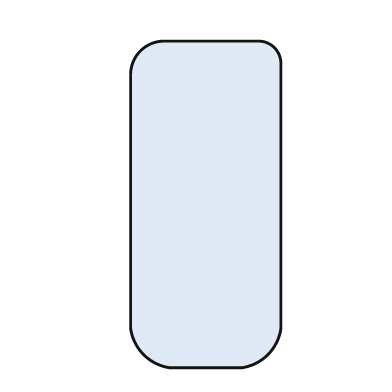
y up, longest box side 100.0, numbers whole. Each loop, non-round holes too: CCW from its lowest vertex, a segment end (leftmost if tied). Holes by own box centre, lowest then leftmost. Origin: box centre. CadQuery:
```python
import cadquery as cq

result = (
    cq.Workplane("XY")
    .moveTo(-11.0, -50.0)
    .lineTo(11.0, -50.0)
    .threePointArc((19.0, -46.0), (23.0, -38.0))
    .lineTo(23.0, 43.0)
    .threePointArc((21.0, 48.0), (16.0, 50.0))
    .lineTo(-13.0, 50.0)
    .threePointArc((-20.0, 47.0), (-23.0, 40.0))
    .lineTo(-23.0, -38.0)
    .threePointArc((-19.0, -46.0), (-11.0, -50.0))
    .close()
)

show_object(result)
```